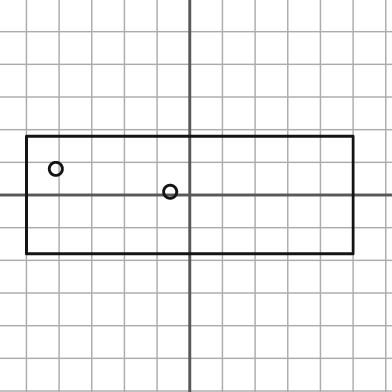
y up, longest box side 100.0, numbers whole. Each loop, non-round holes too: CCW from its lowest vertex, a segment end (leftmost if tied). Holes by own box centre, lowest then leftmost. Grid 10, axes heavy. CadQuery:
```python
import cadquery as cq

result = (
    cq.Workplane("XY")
    .moveTo(-50.0, -18.0)
    .lineTo(50.0, -18.0)
    .lineTo(50.0, 18.0)
    .lineTo(-50.0, 18.0)
    .close()
    .moveTo(-6.0, 1.0)
    .circle(2.0)
    .moveTo(-41.0, 8.0)
    .circle(2.0)
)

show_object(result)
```